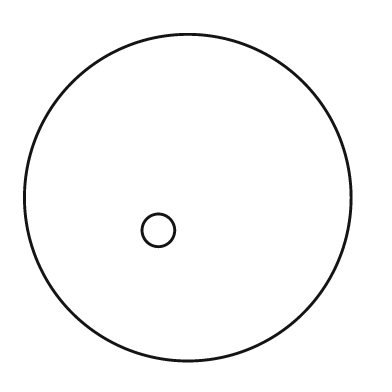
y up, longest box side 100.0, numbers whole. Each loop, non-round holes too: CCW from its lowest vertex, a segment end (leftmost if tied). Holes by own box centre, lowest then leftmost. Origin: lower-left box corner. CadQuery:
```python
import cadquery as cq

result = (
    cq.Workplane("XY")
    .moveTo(50.0, 50.0)
    .circle(50.0)
    .moveTo(41.0, 40.0)
    .circle(5.0)
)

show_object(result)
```